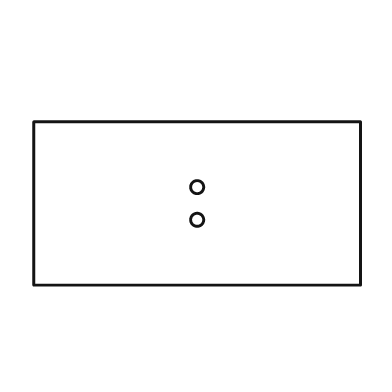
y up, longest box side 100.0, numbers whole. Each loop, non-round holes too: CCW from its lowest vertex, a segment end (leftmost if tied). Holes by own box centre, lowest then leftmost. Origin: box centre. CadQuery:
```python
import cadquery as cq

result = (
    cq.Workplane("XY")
    .moveTo(-50.0, -25.0)
    .lineTo(50.0, -25.0)
    .lineTo(50.0, 25.0)
    .lineTo(-50.0, 25.0)
    .close()
    .moveTo(0.0, -5.0)
    .circle(2.0)
    .moveTo(0.0, 5.0)
    .circle(2.0)
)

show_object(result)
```